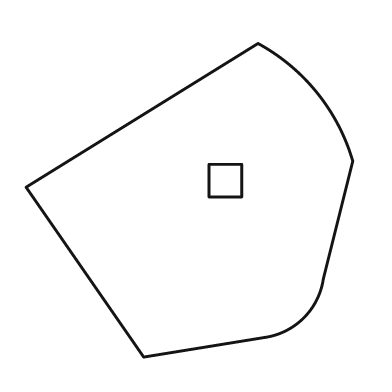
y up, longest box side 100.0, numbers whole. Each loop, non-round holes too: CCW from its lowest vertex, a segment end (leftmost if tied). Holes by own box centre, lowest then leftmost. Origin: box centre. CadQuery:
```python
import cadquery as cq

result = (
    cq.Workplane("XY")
    .moveTo(-14.0, -48.0)
    .lineTo(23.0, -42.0)
    .threePointArc((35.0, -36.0), (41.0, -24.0))
    .lineTo(50.0, 12.0)
    .threePointArc((39.0, 33.0), (21.0, 48.0))
    .lineTo(-50.0, 4.0)
    .close()
    .moveTo(6.0, 1.0)
    .lineTo(16.0, 1.0)
    .lineTo(16.0, 11.0)
    .lineTo(6.0, 11.0)
    .close()
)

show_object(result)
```